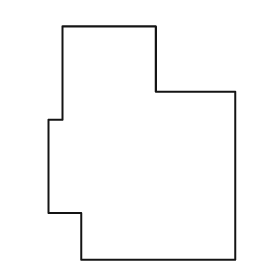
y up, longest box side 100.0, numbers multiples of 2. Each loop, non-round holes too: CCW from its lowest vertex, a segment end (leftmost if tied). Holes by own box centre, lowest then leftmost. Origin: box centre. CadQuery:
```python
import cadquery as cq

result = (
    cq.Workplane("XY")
    .moveTo(-26.0, -50.0)
    .lineTo(40.0, -50.0)
    .lineTo(40.0, 22.0)
    .lineTo(6.0, 22.0)
    .lineTo(6.0, 50.0)
    .lineTo(-34.0, 50.0)
    .lineTo(-34.0, 10.0)
    .lineTo(-40.0, 10.0)
    .lineTo(-40.0, -30.0)
    .lineTo(-26.0, -30.0)
    .close()
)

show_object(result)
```